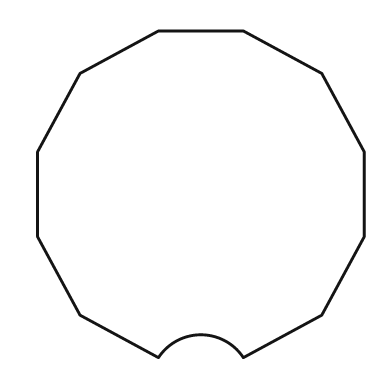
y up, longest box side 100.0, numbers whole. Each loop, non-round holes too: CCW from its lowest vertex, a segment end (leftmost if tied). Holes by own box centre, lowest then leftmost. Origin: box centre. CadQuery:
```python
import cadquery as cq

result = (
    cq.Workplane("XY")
    .moveTo(-13.0, -50.0)
    .threePointArc((0.0, -43.0), (13.0, -50.0))
    .lineTo(37.0, -37.0)
    .lineTo(50.0, -13.0)
    .lineTo(50.0, 13.0)
    .lineTo(37.0, 37.0)
    .lineTo(13.0, 50.0)
    .lineTo(-13.0, 50.0)
    .lineTo(-37.0, 37.0)
    .lineTo(-50.0, 13.0)
    .lineTo(-50.0, -13.0)
    .lineTo(-37.0, -37.0)
    .close()
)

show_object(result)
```